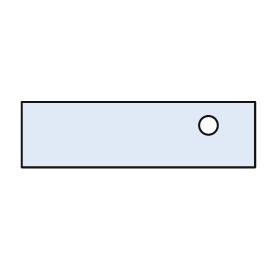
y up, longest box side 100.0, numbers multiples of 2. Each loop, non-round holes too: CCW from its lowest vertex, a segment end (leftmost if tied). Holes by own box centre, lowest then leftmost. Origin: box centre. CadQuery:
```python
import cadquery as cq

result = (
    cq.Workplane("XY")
    .moveTo(-50.0, -14.0)
    .lineTo(50.0, -14.0)
    .lineTo(50.0, 14.0)
    .lineTo(-50.0, 14.0)
    .close()
    .moveTo(30.0, 4.0)
    .circle(4.0)
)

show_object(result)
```